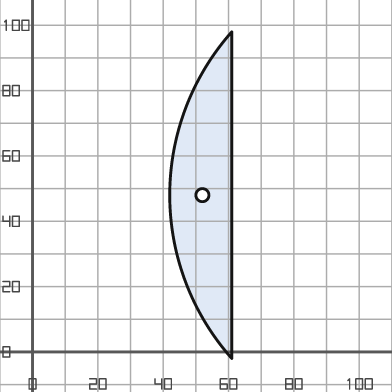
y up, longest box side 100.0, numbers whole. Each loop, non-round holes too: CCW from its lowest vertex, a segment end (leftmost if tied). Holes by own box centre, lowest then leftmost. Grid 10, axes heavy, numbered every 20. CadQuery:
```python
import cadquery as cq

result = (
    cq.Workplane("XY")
    .moveTo(61.0, -2.0)
    .lineTo(61.0, 98.0)
    .threePointArc((42.0, 48.0), (61.0, -2.0))
    .close()
    .moveTo(52.0, 48.0)
    .circle(2.0)
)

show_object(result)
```